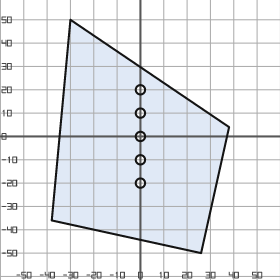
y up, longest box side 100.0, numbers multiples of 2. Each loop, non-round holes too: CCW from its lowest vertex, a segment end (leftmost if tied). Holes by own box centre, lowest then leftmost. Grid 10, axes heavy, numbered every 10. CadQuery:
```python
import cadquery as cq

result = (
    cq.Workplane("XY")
    .moveTo(26.0, -50.0)
    .lineTo(38.0, 4.0)
    .lineTo(-30.0, 50.0)
    .lineTo(-38.0, -36.0)
    .close()
    .moveTo(0.0, -20.0)
    .circle(2.0)
    .moveTo(0.0, -10.0)
    .circle(2.0)
    .moveTo(0.0, 0.0)
    .circle(2.0)
    .moveTo(0.0, 10.0)
    .circle(2.0)
    .moveTo(0.0, 20.0)
    .circle(2.0)
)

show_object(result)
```